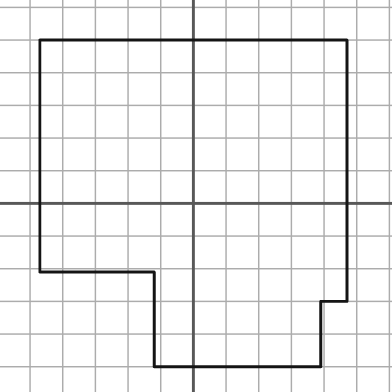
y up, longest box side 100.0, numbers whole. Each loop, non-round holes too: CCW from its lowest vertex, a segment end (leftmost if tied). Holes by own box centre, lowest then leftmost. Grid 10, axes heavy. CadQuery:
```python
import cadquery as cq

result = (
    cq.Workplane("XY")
    .moveTo(-12.0, -50.0)
    .lineTo(39.0, -50.0)
    .lineTo(39.0, -30.0)
    .lineTo(47.0, -30.0)
    .lineTo(47.0, 50.0)
    .lineTo(-47.0, 50.0)
    .lineTo(-47.0, -21.0)
    .lineTo(-12.0, -21.0)
    .close()
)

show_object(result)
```